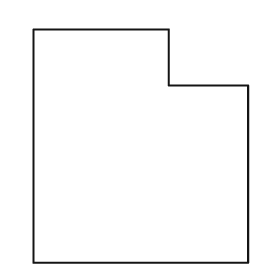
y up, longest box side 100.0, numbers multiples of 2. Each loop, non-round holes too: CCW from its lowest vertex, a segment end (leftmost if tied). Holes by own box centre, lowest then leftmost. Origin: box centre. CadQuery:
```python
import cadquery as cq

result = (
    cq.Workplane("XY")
    .moveTo(-46.0, -50.0)
    .lineTo(46.0, -50.0)
    .lineTo(46.0, 26.0)
    .lineTo(12.0, 26.0)
    .lineTo(12.0, 50.0)
    .lineTo(-46.0, 50.0)
    .close()
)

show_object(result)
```